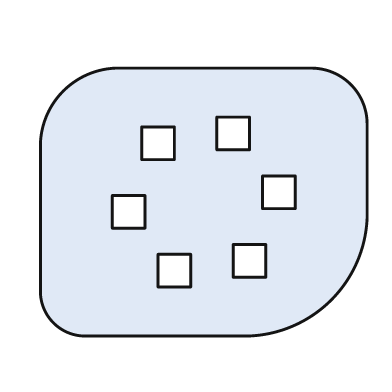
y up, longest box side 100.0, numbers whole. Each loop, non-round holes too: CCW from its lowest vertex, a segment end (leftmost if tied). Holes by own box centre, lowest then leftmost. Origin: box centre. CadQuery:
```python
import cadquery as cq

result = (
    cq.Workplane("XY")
    .moveTo(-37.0, -41.0)
    .lineTo(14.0, -41.0)
    .threePointArc((39.0, -30.0), (50.0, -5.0))
    .lineTo(50.0, 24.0)
    .threePointArc((45.0, 36.0), (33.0, 41.0))
    .lineTo(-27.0, 41.0)
    .threePointArc((-43.0, 34.0), (-50.0, 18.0))
    .lineTo(-50.0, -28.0)
    .threePointArc((-46.0, -37.0), (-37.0, -41.0))
    .close()
    .moveTo(-14.0, -26.0)
    .lineTo(-4.0, -26.0)
    .lineTo(-4.0, -16.0)
    .lineTo(-14.0, -16.0)
    .close()
    .moveTo(9.0, -23.0)
    .lineTo(19.0, -23.0)
    .lineTo(19.0, -13.0)
    .lineTo(9.0, -13.0)
    .close()
    .moveTo(-28.0, -8.0)
    .lineTo(-18.0, -8.0)
    .lineTo(-18.0, 2.0)
    .lineTo(-28.0, 2.0)
    .close()
    .moveTo(18.0, -2.0)
    .lineTo(28.0, -2.0)
    .lineTo(28.0, 8.0)
    .lineTo(18.0, 8.0)
    .close()
    .moveTo(-19.0, 13.0)
    .lineTo(-9.0, 13.0)
    .lineTo(-9.0, 23.0)
    .lineTo(-19.0, 23.0)
    .close()
    .moveTo(4.0, 16.0)
    .lineTo(14.0, 16.0)
    .lineTo(14.0, 26.0)
    .lineTo(4.0, 26.0)
    .close()
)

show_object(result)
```